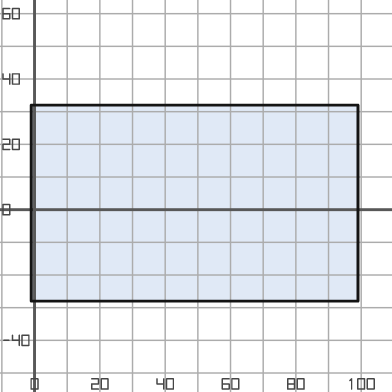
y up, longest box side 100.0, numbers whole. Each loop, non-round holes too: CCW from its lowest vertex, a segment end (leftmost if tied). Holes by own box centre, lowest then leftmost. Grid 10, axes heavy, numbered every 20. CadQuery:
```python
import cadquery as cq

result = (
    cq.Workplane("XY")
    .moveTo(-1.0, -28.0)
    .lineTo(99.0, -28.0)
    .lineTo(99.0, 32.0)
    .lineTo(-1.0, 32.0)
    .close()
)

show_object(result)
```